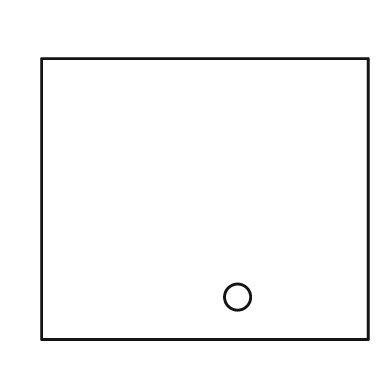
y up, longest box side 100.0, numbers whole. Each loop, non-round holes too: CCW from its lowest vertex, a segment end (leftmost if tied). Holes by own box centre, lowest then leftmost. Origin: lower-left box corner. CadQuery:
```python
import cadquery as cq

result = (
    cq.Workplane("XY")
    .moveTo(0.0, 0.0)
    .lineTo(100.0, 0.0)
    .lineTo(100.0, 86.0)
    .lineTo(0.0, 86.0)
    .close()
    .moveTo(60.0, 13.0)
    .circle(4.0)
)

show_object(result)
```